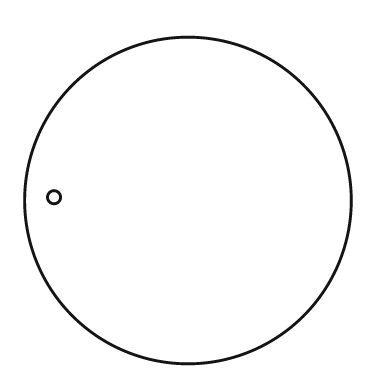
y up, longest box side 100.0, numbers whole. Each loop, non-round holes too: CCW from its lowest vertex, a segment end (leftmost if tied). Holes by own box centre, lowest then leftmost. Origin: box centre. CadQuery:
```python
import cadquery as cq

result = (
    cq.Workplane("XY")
    .moveTo(0.0, 0.0)
    .circle(50.0)
    .moveTo(-41.0, 1.0)
    .circle(2.0)
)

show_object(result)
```